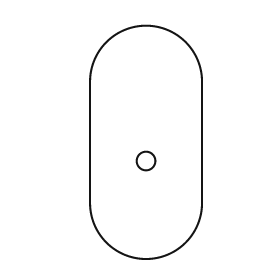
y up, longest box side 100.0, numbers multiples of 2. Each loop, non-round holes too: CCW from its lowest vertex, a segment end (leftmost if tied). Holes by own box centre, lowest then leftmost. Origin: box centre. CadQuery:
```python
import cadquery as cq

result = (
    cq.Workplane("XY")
    .moveTo(-24.0, -26.0)
    .threePointArc((0.0, -50.0), (24.0, -26.0))
    .lineTo(24.0, 26.0)
    .threePointArc((0.0, 50.0), (-24.0, 26.0))
    .close()
    .moveTo(0.0, -8.0)
    .circle(4.0)
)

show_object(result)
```